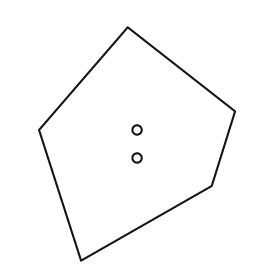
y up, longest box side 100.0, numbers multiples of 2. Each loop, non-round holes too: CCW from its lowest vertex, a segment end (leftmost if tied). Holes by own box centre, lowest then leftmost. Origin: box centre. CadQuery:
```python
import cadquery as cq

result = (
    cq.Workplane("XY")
    .moveTo(-24.0, -50.0)
    .lineTo(32.0, -18.0)
    .lineTo(42.0, 14.0)
    .lineTo(-4.0, 50.0)
    .lineTo(-42.0, 6.0)
    .close()
    .moveTo(0.0, -6.0)
    .circle(2.0)
    .moveTo(0.0, 6.0)
    .circle(2.0)
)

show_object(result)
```